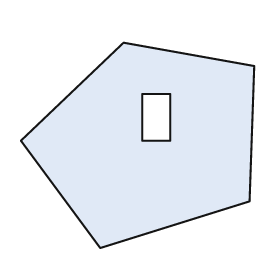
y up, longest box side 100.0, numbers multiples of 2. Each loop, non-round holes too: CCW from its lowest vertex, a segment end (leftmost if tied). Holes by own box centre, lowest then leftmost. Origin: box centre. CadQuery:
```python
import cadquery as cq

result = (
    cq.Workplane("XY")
    .moveTo(-16.0, -44.0)
    .lineTo(48.0, -24.0)
    .lineTo(50.0, 34.0)
    .lineTo(-6.0, 44.0)
    .lineTo(-50.0, 2.0)
    .close()
    .moveTo(2.0, 2.0)
    .lineTo(14.0, 2.0)
    .lineTo(14.0, 22.0)
    .lineTo(2.0, 22.0)
    .close()
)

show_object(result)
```